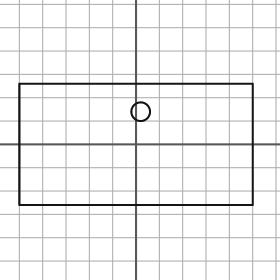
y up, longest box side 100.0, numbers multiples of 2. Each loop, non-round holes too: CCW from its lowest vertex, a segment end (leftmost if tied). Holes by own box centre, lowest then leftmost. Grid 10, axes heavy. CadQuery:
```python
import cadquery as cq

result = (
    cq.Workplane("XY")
    .moveTo(-50.0, -26.0)
    .lineTo(50.0, -26.0)
    .lineTo(50.0, 26.0)
    .lineTo(-50.0, 26.0)
    .close()
    .moveTo(2.0, 14.0)
    .circle(4.0)
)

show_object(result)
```